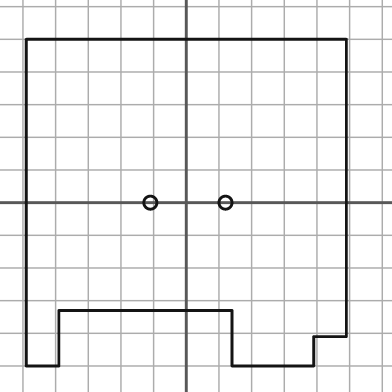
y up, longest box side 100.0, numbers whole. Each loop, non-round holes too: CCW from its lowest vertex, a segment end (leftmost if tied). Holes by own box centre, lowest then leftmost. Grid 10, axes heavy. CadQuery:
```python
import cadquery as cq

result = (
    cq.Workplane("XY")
    .moveTo(-49.0, -50.0)
    .lineTo(-39.0, -50.0)
    .lineTo(-39.0, -33.0)
    .lineTo(14.0, -33.0)
    .lineTo(14.0, -50.0)
    .lineTo(39.0, -50.0)
    .lineTo(39.0, -41.0)
    .lineTo(49.0, -41.0)
    .lineTo(49.0, 50.0)
    .lineTo(-49.0, 50.0)
    .close()
    .moveTo(-11.0, 0.0)
    .circle(2.0)
    .moveTo(12.0, 0.0)
    .circle(2.0)
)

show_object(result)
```